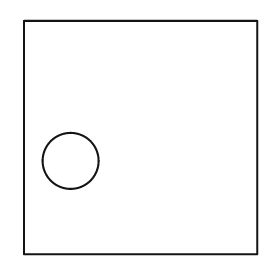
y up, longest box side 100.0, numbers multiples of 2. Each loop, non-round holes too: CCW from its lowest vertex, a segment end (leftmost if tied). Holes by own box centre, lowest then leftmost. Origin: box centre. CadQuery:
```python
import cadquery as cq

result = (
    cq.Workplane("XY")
    .moveTo(-50.0, -50.0)
    .lineTo(50.0, -50.0)
    .lineTo(50.0, 50.0)
    .lineTo(-50.0, 50.0)
    .close()
    .moveTo(-30.0, -10.0)
    .circle(12.0)
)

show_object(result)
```